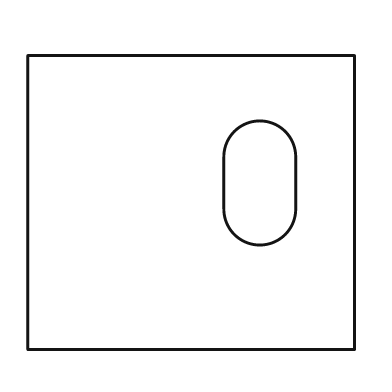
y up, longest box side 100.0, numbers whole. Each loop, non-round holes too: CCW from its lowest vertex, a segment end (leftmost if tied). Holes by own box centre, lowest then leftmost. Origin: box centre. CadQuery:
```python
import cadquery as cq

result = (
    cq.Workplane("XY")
    .moveTo(-50.0, -45.0)
    .lineTo(50.0, -45.0)
    .lineTo(50.0, 45.0)
    .lineTo(-50.0, 45.0)
    .close()
    .moveTo(10.0, -2.0)
    .threePointArc((21.0, -13.0), (32.0, -2.0))
    .lineTo(32.0, 14.0)
    .threePointArc((21.0, 25.0), (10.0, 14.0))
    .close()
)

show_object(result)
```